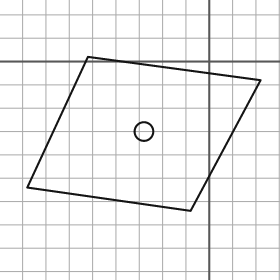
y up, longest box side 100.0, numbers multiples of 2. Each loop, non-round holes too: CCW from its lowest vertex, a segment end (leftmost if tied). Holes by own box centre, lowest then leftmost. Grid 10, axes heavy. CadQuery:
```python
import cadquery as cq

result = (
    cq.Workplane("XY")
    .moveTo(-8.0, -64.0)
    .lineTo(22.0, -8.0)
    .lineTo(-52.0, 2.0)
    .lineTo(-78.0, -54.0)
    .close()
    .moveTo(-28.0, -30.0)
    .circle(4.0)
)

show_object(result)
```